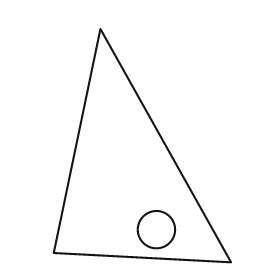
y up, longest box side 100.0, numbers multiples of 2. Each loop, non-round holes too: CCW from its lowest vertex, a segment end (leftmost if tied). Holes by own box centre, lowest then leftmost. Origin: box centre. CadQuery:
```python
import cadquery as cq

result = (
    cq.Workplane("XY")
    .moveTo(38.0, -50.0)
    .lineTo(-18.0, 50.0)
    .lineTo(-38.0, -46.0)
    .close()
    .moveTo(6.0, -36.0)
    .circle(8.0)
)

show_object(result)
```